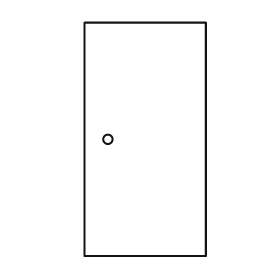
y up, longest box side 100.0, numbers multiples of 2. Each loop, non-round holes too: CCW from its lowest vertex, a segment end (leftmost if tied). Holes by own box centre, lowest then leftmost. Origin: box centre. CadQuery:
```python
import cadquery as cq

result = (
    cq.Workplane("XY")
    .moveTo(-26.0, -50.0)
    .lineTo(26.0, -50.0)
    .lineTo(26.0, 50.0)
    .lineTo(-26.0, 50.0)
    .close()
    .moveTo(-16.0, 0.0)
    .circle(2.0)
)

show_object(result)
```